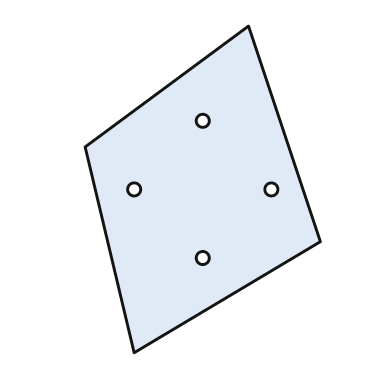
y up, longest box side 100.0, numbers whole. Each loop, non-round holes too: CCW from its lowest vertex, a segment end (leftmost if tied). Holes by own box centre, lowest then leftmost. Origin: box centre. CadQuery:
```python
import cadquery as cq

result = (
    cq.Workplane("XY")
    .moveTo(-21.0, -50.0)
    .lineTo(36.0, -16.0)
    .lineTo(14.0, 50.0)
    .lineTo(-36.0, 13.0)
    .close()
    .moveTo(0.0, -21.0)
    .circle(2.0)
    .moveTo(-21.0, 0.0)
    .circle(2.0)
    .moveTo(21.0, 0.0)
    .circle(2.0)
    .moveTo(0.0, 21.0)
    .circle(2.0)
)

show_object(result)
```